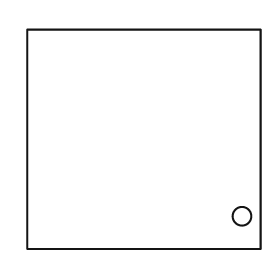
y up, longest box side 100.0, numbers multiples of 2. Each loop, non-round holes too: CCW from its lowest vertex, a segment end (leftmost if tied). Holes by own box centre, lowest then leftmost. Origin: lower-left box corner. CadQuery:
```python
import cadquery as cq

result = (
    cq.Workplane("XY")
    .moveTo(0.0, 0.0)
    .lineTo(100.0, 0.0)
    .lineTo(100.0, 94.0)
    .lineTo(0.0, 94.0)
    .close()
    .moveTo(92.0, 14.0)
    .circle(4.0)
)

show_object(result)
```